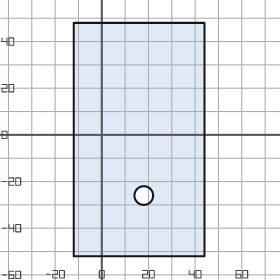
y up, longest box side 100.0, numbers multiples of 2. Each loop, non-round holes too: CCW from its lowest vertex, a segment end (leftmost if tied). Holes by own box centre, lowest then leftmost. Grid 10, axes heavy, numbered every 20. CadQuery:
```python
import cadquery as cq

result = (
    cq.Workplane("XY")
    .moveTo(-12.0, -52.0)
    .lineTo(44.0, -52.0)
    .lineTo(44.0, 48.0)
    .lineTo(-12.0, 48.0)
    .close()
    .moveTo(18.0, -26.0)
    .circle(4.0)
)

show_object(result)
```